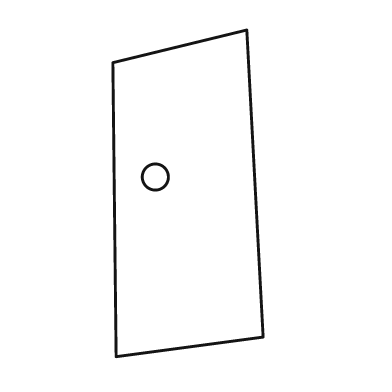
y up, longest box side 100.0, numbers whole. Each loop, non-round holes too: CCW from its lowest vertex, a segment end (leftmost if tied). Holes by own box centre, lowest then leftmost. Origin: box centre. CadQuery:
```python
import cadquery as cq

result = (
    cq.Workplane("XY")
    .moveTo(-22.0, -50.0)
    .lineTo(23.0, -44.0)
    .lineTo(18.0, 50.0)
    .lineTo(-23.0, 40.0)
    .close()
    .moveTo(-10.0, 5.0)
    .circle(4.0)
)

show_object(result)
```